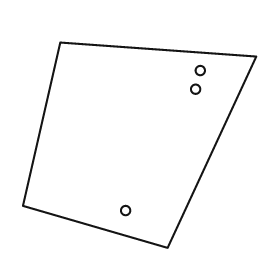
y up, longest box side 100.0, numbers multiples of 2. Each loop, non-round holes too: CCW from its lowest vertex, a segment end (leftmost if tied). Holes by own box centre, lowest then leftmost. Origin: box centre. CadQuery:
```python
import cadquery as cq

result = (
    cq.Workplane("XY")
    .moveTo(12.0, -44.0)
    .lineTo(50.0, 38.0)
    .lineTo(-34.0, 44.0)
    .lineTo(-50.0, -26.0)
    .close()
    .moveTo(-6.0, -28.0)
    .circle(2.0)
    .moveTo(24.0, 24.0)
    .circle(2.0)
    .moveTo(26.0, 32.0)
    .circle(2.0)
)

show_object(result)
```